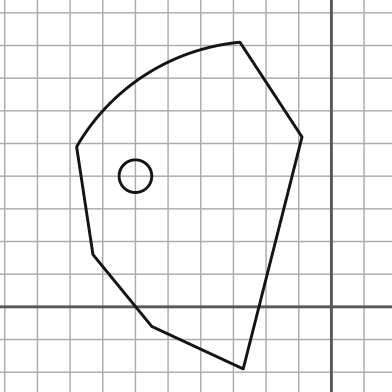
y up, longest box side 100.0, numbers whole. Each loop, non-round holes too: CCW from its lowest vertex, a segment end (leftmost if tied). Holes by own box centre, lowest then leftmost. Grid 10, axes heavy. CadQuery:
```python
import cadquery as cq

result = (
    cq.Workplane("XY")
    .moveTo(-27.0, -19.0)
    .lineTo(-9.0, 52.0)
    .lineTo(-28.0, 81.0)
    .threePointArc((-57.0, 71.0), (-78.0, 49.0))
    .lineTo(-73.0, 16.0)
    .lineTo(-55.0, -6.0)
    .close()
    .moveTo(-60.0, 40.0)
    .circle(5.0)
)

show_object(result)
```